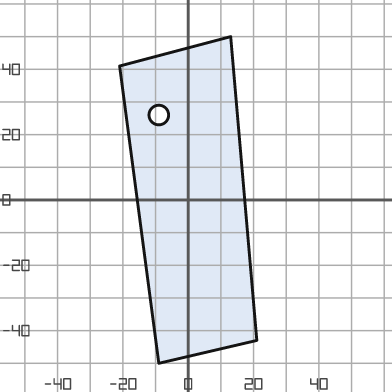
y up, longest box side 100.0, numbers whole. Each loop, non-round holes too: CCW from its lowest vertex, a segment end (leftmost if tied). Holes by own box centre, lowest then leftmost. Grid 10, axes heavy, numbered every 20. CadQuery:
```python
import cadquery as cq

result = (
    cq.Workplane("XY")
    .moveTo(-9.0, -50.0)
    .lineTo(21.0, -43.0)
    .lineTo(13.0, 50.0)
    .lineTo(-21.0, 41.0)
    .close()
    .moveTo(-9.0, 26.0)
    .circle(3.0)
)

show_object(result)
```